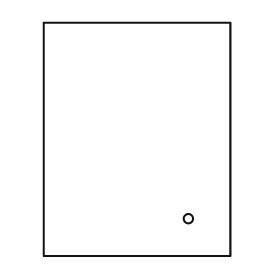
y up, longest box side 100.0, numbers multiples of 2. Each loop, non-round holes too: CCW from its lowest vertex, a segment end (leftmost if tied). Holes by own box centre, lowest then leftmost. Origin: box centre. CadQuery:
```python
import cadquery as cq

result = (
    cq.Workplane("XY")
    .moveTo(-40.0, -50.0)
    .lineTo(40.0, -50.0)
    .lineTo(40.0, 50.0)
    .lineTo(-40.0, 50.0)
    .close()
    .moveTo(22.0, -34.0)
    .circle(2.0)
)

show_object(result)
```